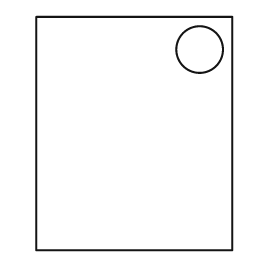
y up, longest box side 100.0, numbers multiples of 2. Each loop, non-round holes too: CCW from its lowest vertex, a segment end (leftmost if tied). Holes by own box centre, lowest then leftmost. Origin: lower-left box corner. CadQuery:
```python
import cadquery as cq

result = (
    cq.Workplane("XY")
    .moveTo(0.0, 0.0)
    .lineTo(84.0, 0.0)
    .lineTo(84.0, 100.0)
    .lineTo(0.0, 100.0)
    .close()
    .moveTo(70.0, 86.0)
    .circle(10.0)
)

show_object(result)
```